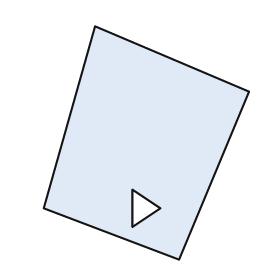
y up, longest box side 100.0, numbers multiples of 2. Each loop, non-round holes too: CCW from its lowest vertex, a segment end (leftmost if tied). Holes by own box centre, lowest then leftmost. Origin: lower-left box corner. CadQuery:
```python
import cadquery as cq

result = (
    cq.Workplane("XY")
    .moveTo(58.0, 0.0)
    .lineTo(88.0, 72.0)
    .lineTo(22.0, 100.0)
    .lineTo(0.0, 22.0)
    .close()
    .moveTo(38.0, 14.0)
    .lineTo(50.0, 22.0)
    .lineTo(38.0, 30.0)
    .close()
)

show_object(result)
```